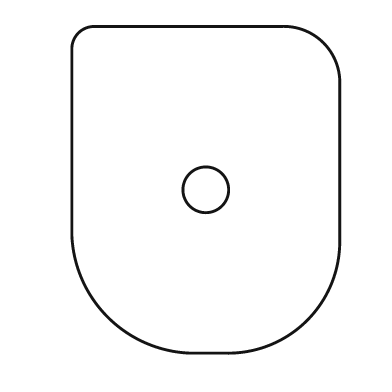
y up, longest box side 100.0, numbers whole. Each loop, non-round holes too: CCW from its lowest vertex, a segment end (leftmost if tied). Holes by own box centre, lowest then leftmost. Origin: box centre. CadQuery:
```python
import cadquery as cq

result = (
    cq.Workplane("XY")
    .moveTo(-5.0, -50.0)
    .lineTo(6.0, -50.0)
    .threePointArc((31.0, -40.0), (41.0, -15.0))
    .lineTo(41.0, 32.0)
    .threePointArc((36.0, 45.0), (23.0, 50.0))
    .lineTo(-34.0, 50.0)
    .threePointArc((-39.0, 48.0), (-41.0, 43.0))
    .lineTo(-41.0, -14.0)
    .threePointArc((-30.0, -39.0), (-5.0, -50.0))
    .close()
    .moveTo(0.0, 0.0)
    .circle(7.0)
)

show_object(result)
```